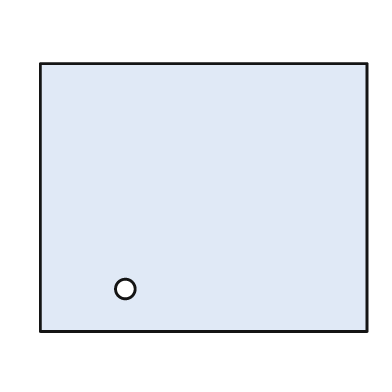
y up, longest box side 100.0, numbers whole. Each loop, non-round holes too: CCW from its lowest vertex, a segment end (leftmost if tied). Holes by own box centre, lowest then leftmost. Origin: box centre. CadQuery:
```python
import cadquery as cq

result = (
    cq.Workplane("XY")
    .moveTo(-50.0, -41.0)
    .lineTo(50.0, -41.0)
    .lineTo(50.0, 41.0)
    .lineTo(-50.0, 41.0)
    .close()
    .moveTo(-24.0, -28.0)
    .circle(3.0)
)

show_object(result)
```